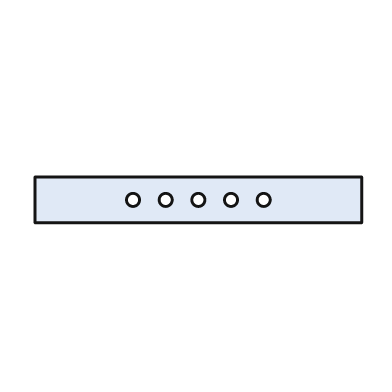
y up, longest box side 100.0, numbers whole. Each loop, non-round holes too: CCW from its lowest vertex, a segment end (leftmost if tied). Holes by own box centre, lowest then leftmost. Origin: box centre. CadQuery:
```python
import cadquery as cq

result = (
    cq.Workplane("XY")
    .moveTo(-50.0, -7.0)
    .lineTo(50.0, -7.0)
    .lineTo(50.0, 7.0)
    .lineTo(-50.0, 7.0)
    .close()
    .moveTo(-20.0, 0.0)
    .circle(2.0)
    .moveTo(-10.0, 0.0)
    .circle(2.0)
    .moveTo(0.0, 0.0)
    .circle(2.0)
    .moveTo(10.0, 0.0)
    .circle(2.0)
    .moveTo(20.0, 0.0)
    .circle(2.0)
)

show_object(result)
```